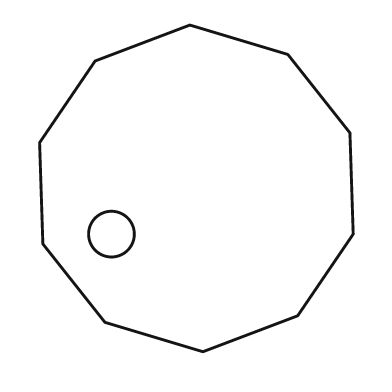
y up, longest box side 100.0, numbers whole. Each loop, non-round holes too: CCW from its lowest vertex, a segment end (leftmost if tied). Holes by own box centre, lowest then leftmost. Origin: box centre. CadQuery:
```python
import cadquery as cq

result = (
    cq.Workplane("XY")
    .moveTo(2.0, -50.0)
    .lineTo(31.0, -39.0)
    .lineTo(48.0, -14.0)
    .lineTo(47.0, 17.0)
    .lineTo(28.0, 41.0)
    .lineTo(-2.0, 50.0)
    .lineTo(-31.0, 39.0)
    .lineTo(-48.0, 14.0)
    .lineTo(-47.0, -17.0)
    .lineTo(-28.0, -41.0)
    .close()
    .moveTo(-26.0, -14.0)
    .circle(7.0)
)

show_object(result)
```